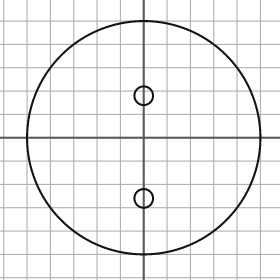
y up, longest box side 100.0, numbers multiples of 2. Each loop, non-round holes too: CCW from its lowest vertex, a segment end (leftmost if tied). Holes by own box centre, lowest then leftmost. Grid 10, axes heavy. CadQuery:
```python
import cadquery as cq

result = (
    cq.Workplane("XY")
    .moveTo(0.0, 0.0)
    .circle(50.0)
    .moveTo(0.0, -26.0)
    .circle(4.0)
    .moveTo(0.0, 18.0)
    .circle(4.0)
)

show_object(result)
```